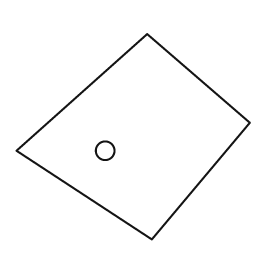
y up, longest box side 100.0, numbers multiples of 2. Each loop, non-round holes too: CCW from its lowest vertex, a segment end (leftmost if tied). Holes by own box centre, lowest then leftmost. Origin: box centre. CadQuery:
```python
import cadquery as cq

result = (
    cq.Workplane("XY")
    .moveTo(8.0, -44.0)
    .lineTo(50.0, 6.0)
    .lineTo(6.0, 44.0)
    .lineTo(-50.0, -6.0)
    .close()
    .moveTo(-12.0, -6.0)
    .circle(4.0)
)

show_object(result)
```